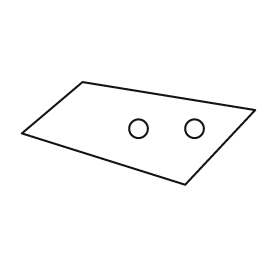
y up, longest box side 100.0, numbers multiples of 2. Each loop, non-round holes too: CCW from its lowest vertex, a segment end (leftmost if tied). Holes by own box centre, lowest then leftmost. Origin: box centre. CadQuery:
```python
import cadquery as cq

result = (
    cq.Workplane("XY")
    .moveTo(20.0, -22.0)
    .lineTo(50.0, 10.0)
    .lineTo(-24.0, 22.0)
    .lineTo(-50.0, 0.0)
    .close()
    .moveTo(0.0, 2.0)
    .circle(4.0)
    .moveTo(24.0, 2.0)
    .circle(4.0)
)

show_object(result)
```